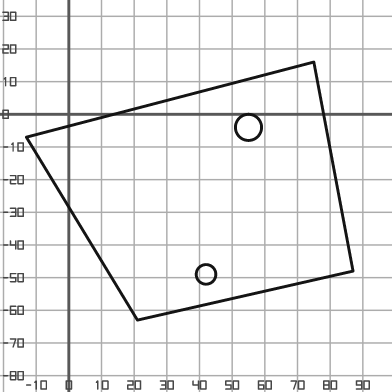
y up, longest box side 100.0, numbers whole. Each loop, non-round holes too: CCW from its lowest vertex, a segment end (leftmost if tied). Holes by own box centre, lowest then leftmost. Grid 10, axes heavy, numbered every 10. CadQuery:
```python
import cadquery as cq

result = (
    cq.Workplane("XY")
    .moveTo(21.0, -63.0)
    .lineTo(87.0, -48.0)
    .lineTo(75.0, 16.0)
    .lineTo(-13.0, -7.0)
    .close()
    .moveTo(42.0, -49.0)
    .circle(3.0)
    .moveTo(55.0, -4.0)
    .circle(4.0)
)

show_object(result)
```